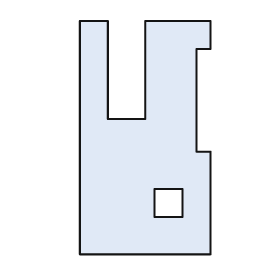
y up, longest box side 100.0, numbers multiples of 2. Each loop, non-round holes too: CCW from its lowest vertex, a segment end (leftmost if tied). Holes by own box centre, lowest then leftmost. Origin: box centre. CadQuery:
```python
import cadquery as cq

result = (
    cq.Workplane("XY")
    .moveTo(-28.0, -50.0)
    .lineTo(28.0, -50.0)
    .lineTo(28.0, -6.0)
    .lineTo(22.0, -6.0)
    .lineTo(22.0, 38.0)
    .lineTo(28.0, 38.0)
    .lineTo(28.0, 50.0)
    .lineTo(0.0, 50.0)
    .lineTo(0.0, 8.0)
    .lineTo(-16.0, 8.0)
    .lineTo(-16.0, 50.0)
    .lineTo(-28.0, 50.0)
    .close()
    .moveTo(4.0, -34.0)
    .lineTo(16.0, -34.0)
    .lineTo(16.0, -22.0)
    .lineTo(4.0, -22.0)
    .close()
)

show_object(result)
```